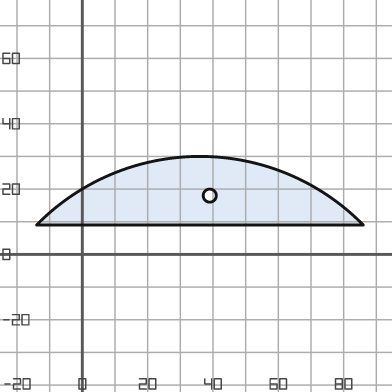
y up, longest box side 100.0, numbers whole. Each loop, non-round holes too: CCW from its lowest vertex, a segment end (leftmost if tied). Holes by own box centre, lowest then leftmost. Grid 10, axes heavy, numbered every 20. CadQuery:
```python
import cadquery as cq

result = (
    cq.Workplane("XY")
    .moveTo(-14.0, 9.0)
    .lineTo(86.0, 9.0)
    .threePointArc((36.0, 30.0), (-14.0, 9.0))
    .close()
    .moveTo(39.0, 18.0)
    .circle(2.0)
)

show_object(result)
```